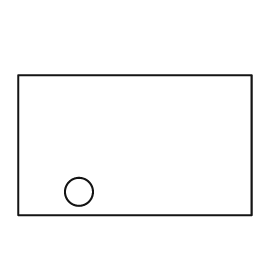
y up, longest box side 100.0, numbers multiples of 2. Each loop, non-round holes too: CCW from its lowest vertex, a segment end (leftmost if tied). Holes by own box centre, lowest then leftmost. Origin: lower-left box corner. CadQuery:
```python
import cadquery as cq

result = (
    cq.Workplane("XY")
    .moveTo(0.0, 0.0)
    .lineTo(100.0, 0.0)
    .lineTo(100.0, 60.0)
    .lineTo(0.0, 60.0)
    .close()
    .moveTo(26.0, 10.0)
    .circle(6.0)
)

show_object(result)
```